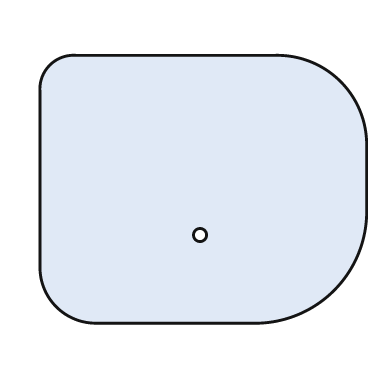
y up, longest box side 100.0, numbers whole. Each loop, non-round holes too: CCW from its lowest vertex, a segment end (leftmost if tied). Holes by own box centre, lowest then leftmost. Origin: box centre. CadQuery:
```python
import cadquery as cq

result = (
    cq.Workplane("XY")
    .moveTo(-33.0, -41.0)
    .lineTo(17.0, -41.0)
    .threePointArc((40.0, -31.0), (50.0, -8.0))
    .lineTo(50.0, 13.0)
    .threePointArc((42.0, 33.0), (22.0, 41.0))
    .lineTo(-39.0, 41.0)
    .threePointArc((-47.0, 38.0), (-50.0, 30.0))
    .lineTo(-50.0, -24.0)
    .threePointArc((-45.0, -36.0), (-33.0, -41.0))
    .close()
    .moveTo(-1.0, -14.0)
    .circle(2.0)
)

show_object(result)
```